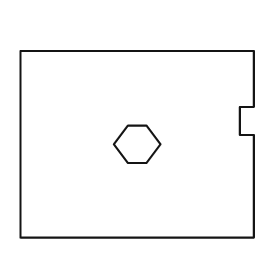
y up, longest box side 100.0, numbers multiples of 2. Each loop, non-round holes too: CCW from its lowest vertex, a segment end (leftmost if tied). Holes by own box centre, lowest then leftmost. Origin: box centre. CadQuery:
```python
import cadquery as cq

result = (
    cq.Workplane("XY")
    .moveTo(-50.0, -40.0)
    .lineTo(50.0, -40.0)
    .lineTo(50.0, 4.0)
    .lineTo(44.0, 4.0)
    .lineTo(44.0, 16.0)
    .lineTo(50.0, 16.0)
    .lineTo(50.0, 40.0)
    .lineTo(-50.0, 40.0)
    .close()
    .moveTo(-4.0, -8.0)
    .lineTo(4.0, -8.0)
    .lineTo(10.0, 0.0)
    .lineTo(4.0, 8.0)
    .lineTo(-4.0, 8.0)
    .lineTo(-10.0, 0.0)
    .close()
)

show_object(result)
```